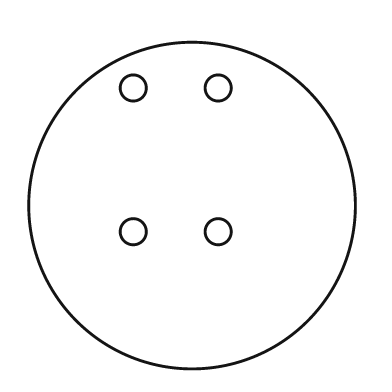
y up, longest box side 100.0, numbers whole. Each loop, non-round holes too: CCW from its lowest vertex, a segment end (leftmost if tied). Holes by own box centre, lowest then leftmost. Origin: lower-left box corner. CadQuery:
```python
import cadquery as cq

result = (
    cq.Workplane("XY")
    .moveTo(50.0, 50.0)
    .circle(50.0)
    .moveTo(32.0, 42.0)
    .circle(4.0)
    .moveTo(58.0, 42.0)
    .circle(4.0)
    .moveTo(32.0, 86.0)
    .circle(4.0)
    .moveTo(58.0, 86.0)
    .circle(4.0)
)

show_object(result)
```